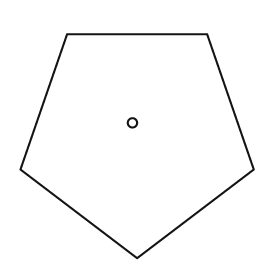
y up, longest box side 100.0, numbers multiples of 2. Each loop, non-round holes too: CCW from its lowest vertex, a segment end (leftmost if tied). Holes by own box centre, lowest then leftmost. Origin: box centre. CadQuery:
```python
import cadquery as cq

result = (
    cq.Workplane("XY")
    .moveTo(0.0, -48.0)
    .lineTo(50.0, -10.0)
    .lineTo(30.0, 48.0)
    .lineTo(-30.0, 48.0)
    .lineTo(-50.0, -10.0)
    .close()
    .moveTo(-2.0, 10.0)
    .circle(2.0)
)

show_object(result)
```